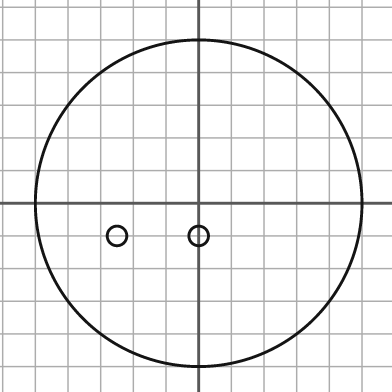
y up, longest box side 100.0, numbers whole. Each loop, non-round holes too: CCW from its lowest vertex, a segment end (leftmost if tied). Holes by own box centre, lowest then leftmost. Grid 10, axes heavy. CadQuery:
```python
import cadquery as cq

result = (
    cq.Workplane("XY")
    .moveTo(0.0, 0.0)
    .circle(50.0)
    .moveTo(-25.0, -10.0)
    .circle(3.0)
    .moveTo(0.0, -10.0)
    .circle(3.0)
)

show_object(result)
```